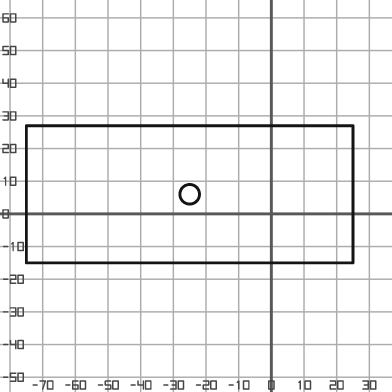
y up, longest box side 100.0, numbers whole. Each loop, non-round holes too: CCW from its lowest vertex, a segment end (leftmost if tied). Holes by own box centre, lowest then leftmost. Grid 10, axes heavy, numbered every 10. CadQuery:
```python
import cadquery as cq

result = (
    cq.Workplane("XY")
    .moveTo(-75.0, -15.0)
    .lineTo(25.0, -15.0)
    .lineTo(25.0, 27.0)
    .lineTo(-75.0, 27.0)
    .close()
    .moveTo(-25.0, 6.0)
    .circle(3.0)
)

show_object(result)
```